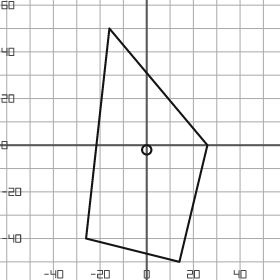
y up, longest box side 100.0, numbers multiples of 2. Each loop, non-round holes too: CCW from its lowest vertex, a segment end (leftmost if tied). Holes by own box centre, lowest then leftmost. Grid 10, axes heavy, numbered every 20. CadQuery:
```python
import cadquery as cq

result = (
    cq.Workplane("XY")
    .moveTo(14.0, -50.0)
    .lineTo(26.0, 0.0)
    .lineTo(-16.0, 50.0)
    .lineTo(-26.0, -40.0)
    .close()
    .moveTo(0.0, -2.0)
    .circle(2.0)
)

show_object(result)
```